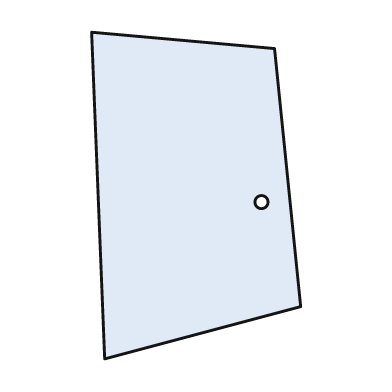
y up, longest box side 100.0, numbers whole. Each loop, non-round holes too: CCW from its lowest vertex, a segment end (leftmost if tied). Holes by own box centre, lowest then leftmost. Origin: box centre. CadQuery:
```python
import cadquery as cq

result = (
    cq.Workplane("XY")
    .moveTo(-28.0, -50.0)
    .lineTo(32.0, -34.0)
    .lineTo(24.0, 45.0)
    .lineTo(-32.0, 50.0)
    .close()
    .moveTo(20.0, -2.0)
    .circle(2.0)
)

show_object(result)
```